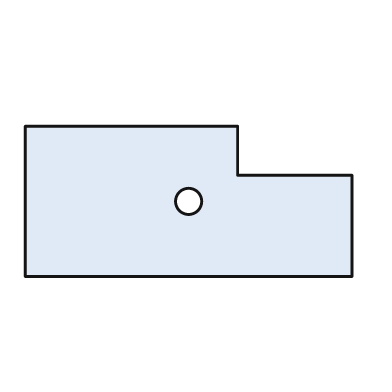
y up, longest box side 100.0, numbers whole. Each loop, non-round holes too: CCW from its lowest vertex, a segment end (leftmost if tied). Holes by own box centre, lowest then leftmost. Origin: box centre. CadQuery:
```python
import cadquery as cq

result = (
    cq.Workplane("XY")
    .moveTo(-50.0, -23.0)
    .lineTo(50.0, -23.0)
    .lineTo(50.0, 8.0)
    .lineTo(15.0, 8.0)
    .lineTo(15.0, 23.0)
    .lineTo(-50.0, 23.0)
    .close()
    .moveTo(0.0, 0.0)
    .circle(4.0)
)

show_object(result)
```